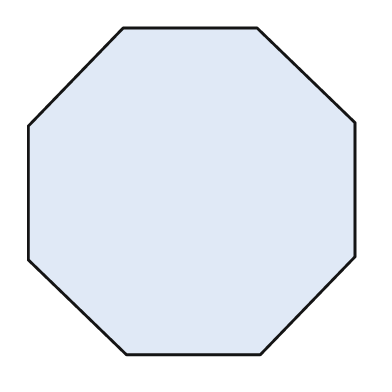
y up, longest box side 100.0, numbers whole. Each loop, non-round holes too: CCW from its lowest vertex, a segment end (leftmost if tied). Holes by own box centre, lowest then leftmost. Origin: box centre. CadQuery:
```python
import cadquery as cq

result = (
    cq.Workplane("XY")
    .moveTo(-20.0, -50.0)
    .lineTo(21.0, -50.0)
    .lineTo(50.0, -20.0)
    .lineTo(50.0, 21.0)
    .lineTo(20.0, 50.0)
    .lineTo(-21.0, 50.0)
    .lineTo(-50.0, 20.0)
    .lineTo(-50.0, -21.0)
    .close()
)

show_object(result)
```